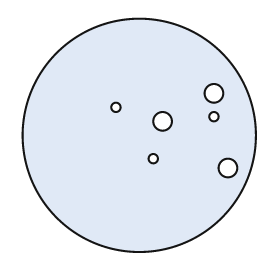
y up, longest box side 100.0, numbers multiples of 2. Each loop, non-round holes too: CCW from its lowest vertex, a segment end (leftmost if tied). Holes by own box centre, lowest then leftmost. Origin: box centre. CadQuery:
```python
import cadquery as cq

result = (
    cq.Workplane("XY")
    .moveTo(0.0, 0.0)
    .circle(50.0)
    .moveTo(38.0, -14.0)
    .circle(4.0)
    .moveTo(6.0, -10.0)
    .circle(2.0)
    .moveTo(10.0, 6.0)
    .circle(4.0)
    .moveTo(32.0, 8.0)
    .circle(2.0)
    .moveTo(-10.0, 12.0)
    .circle(2.0)
    .moveTo(32.0, 18.0)
    .circle(4.0)
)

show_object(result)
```